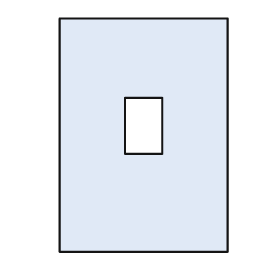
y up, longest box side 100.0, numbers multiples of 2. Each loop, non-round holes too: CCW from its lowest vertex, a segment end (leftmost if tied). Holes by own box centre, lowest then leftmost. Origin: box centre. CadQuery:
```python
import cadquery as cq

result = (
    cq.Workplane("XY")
    .moveTo(-36.0, -50.0)
    .lineTo(36.0, -50.0)
    .lineTo(36.0, 50.0)
    .lineTo(-36.0, 50.0)
    .close()
    .moveTo(-8.0, -8.0)
    .lineTo(8.0, -8.0)
    .lineTo(8.0, 16.0)
    .lineTo(-8.0, 16.0)
    .close()
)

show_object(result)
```